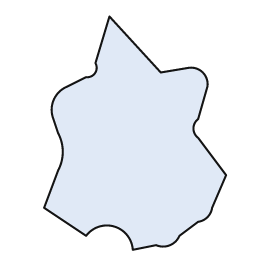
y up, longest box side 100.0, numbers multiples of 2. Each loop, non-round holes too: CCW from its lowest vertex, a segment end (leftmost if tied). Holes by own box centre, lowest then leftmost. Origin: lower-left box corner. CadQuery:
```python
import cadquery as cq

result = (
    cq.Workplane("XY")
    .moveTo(38.0, 0.0)
    .lineTo(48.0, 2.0)
    .threePointArc((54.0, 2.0), (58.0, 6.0))
    .lineTo(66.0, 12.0)
    .threePointArc((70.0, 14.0), (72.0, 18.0))
    .lineTo(78.0, 32.0)
    .lineTo(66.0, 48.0)
    .threePointArc((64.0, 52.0), (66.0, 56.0))
    .lineTo(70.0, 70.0)
    .threePointArc((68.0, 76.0), (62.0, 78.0))
    .lineTo(50.0, 76.0)
    .lineTo(28.0, 100.0)
    .lineTo(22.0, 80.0)
    .threePointArc((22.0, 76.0), (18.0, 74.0))
    .lineTo(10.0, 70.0)
    .threePointArc((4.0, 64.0), (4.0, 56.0))
    .lineTo(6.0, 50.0)
    .threePointArc((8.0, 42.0), (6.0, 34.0))
    .lineTo(0.0, 18.0)
    .lineTo(18.0, 6.0)
    .threePointArc((30.0, 10.0), (38.0, 0.0))
    .close()
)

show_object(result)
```